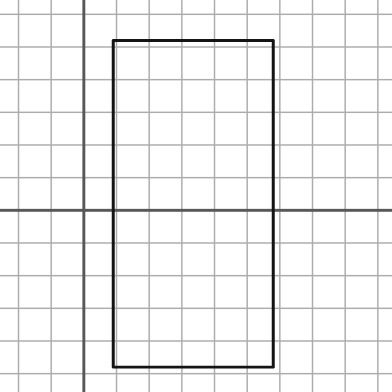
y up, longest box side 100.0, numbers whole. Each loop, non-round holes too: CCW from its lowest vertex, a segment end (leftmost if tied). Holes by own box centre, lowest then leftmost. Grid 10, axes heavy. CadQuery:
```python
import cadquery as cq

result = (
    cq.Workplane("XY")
    .moveTo(9.0, -48.0)
    .lineTo(58.0, -48.0)
    .lineTo(58.0, 52.0)
    .lineTo(9.0, 52.0)
    .close()
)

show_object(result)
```